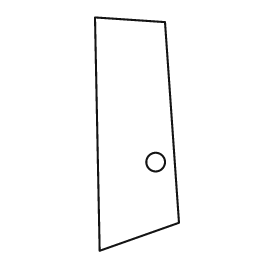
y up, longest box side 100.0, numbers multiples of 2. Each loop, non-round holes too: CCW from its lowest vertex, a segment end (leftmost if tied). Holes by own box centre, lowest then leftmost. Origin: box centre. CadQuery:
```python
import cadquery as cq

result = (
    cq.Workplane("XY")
    .moveTo(-16.0, -50.0)
    .lineTo(18.0, -38.0)
    .lineTo(12.0, 48.0)
    .lineTo(-18.0, 50.0)
    .close()
    .moveTo(8.0, -12.0)
    .circle(4.0)
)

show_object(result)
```